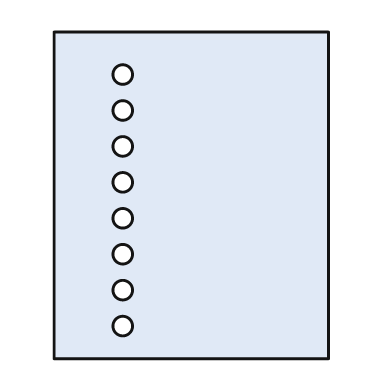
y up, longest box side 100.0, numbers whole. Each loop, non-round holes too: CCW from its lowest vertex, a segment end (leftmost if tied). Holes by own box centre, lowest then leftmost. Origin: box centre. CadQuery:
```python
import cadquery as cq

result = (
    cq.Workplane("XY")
    .moveTo(-42.0, -50.0)
    .lineTo(42.0, -50.0)
    .lineTo(42.0, 50.0)
    .lineTo(-42.0, 50.0)
    .close()
    .moveTo(-21.0, -40.0)
    .circle(3.0)
    .moveTo(-21.0, -29.0)
    .circle(3.0)
    .moveTo(-21.0, -18.0)
    .circle(3.0)
    .moveTo(-21.0, -7.0)
    .circle(3.0)
    .moveTo(-21.0, 4.0)
    .circle(3.0)
    .moveTo(-21.0, 15.0)
    .circle(3.0)
    .moveTo(-21.0, 26.0)
    .circle(3.0)
    .moveTo(-21.0, 37.0)
    .circle(3.0)
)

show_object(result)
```